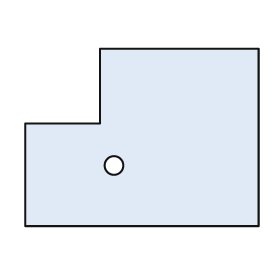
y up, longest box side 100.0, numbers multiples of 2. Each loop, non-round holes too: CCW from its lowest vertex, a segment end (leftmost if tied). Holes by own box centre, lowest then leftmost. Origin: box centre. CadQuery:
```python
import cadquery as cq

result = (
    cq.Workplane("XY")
    .moveTo(-50.0, -38.0)
    .lineTo(50.0, -38.0)
    .lineTo(50.0, 38.0)
    .lineTo(-18.0, 38.0)
    .lineTo(-18.0, 6.0)
    .lineTo(-50.0, 6.0)
    .close()
    .moveTo(-12.0, -12.0)
    .circle(4.0)
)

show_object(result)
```